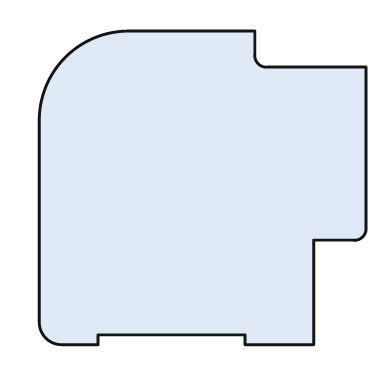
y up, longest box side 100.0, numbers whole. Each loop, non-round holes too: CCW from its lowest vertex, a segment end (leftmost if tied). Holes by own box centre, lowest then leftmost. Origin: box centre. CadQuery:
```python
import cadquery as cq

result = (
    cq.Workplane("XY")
    .moveTo(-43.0, -48.0)
    .lineTo(-32.0, -48.0)
    .lineTo(-32.0, -45.0)
    .lineTo(13.0, -45.0)
    .lineTo(13.0, -48.0)
    .lineTo(34.0, -48.0)
    .lineTo(34.0, -16.0)
    .lineTo(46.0, -16.0)
    .threePointArc((49.0, -15.0), (50.0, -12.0))
    .lineTo(50.0, 37.0)
    .lineTo(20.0, 37.0)
    .threePointArc((17.0, 38.0), (16.0, 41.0))
    .lineTo(16.0, 48.0)
    .lineTo(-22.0, 48.0)
    .threePointArc((-42.0, 40.0), (-50.0, 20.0))
    .lineTo(-50.0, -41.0)
    .threePointArc((-48.0, -46.0), (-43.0, -48.0))
    .close()
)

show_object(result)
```